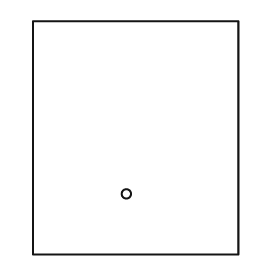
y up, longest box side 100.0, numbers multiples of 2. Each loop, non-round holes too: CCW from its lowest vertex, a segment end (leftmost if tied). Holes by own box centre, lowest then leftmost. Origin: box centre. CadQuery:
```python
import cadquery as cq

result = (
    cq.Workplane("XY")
    .moveTo(-44.0, -50.0)
    .lineTo(44.0, -50.0)
    .lineTo(44.0, 50.0)
    .lineTo(-44.0, 50.0)
    .close()
    .moveTo(-4.0, -24.0)
    .circle(2.0)
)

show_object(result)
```